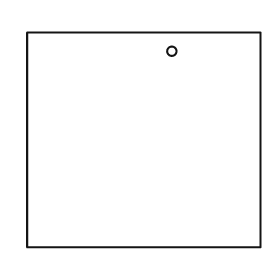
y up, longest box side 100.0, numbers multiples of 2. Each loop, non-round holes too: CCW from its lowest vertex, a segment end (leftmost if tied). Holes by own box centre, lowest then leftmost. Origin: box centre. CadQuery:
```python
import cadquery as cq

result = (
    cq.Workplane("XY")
    .moveTo(-50.0, -46.0)
    .lineTo(50.0, -46.0)
    .lineTo(50.0, 46.0)
    .lineTo(-50.0, 46.0)
    .close()
    .moveTo(12.0, 38.0)
    .circle(2.0)
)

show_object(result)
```